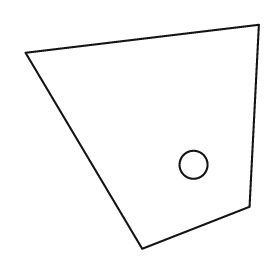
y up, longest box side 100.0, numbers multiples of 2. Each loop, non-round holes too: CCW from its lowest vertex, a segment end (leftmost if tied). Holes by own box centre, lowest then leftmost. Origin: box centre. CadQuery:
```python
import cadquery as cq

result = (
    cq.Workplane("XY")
    .moveTo(0.0, -48.0)
    .lineTo(46.0, -30.0)
    .lineTo(50.0, 48.0)
    .lineTo(-50.0, 36.0)
    .close()
    .moveTo(22.0, -12.0)
    .circle(6.0)
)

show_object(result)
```